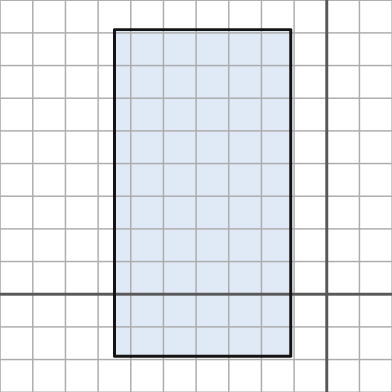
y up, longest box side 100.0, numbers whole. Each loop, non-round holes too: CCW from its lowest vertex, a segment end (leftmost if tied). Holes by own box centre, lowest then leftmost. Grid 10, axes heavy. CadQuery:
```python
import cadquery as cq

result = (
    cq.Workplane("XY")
    .moveTo(-65.0, -19.0)
    .lineTo(-11.0, -19.0)
    .lineTo(-11.0, 81.0)
    .lineTo(-65.0, 81.0)
    .close()
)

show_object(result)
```